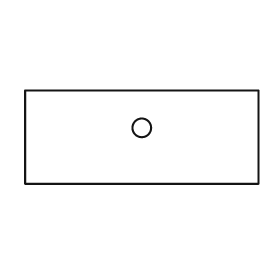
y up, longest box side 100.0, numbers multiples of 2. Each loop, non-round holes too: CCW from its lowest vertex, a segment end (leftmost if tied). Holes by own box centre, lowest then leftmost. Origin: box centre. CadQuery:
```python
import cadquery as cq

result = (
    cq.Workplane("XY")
    .moveTo(-50.0, -20.0)
    .lineTo(50.0, -20.0)
    .lineTo(50.0, 20.0)
    .lineTo(-50.0, 20.0)
    .close()
    .moveTo(0.0, 4.0)
    .circle(4.0)
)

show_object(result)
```